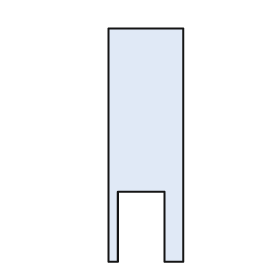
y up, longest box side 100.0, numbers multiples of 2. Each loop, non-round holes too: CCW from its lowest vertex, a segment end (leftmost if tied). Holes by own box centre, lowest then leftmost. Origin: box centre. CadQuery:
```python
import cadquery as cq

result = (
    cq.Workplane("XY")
    .moveTo(-16.0, -50.0)
    .lineTo(-12.0, -50.0)
    .lineTo(-12.0, -20.0)
    .lineTo(8.0, -20.0)
    .lineTo(8.0, -50.0)
    .lineTo(16.0, -50.0)
    .lineTo(16.0, 50.0)
    .lineTo(-16.0, 50.0)
    .close()
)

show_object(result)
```